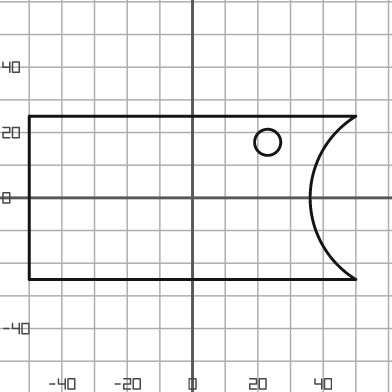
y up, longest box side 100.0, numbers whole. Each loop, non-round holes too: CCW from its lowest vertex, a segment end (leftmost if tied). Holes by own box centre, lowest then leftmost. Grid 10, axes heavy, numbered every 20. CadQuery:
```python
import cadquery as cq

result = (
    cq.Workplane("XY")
    .moveTo(-50.0, -25.0)
    .lineTo(50.0, -25.0)
    .threePointArc((36.0, 0.0), (50.0, 25.0))
    .lineTo(-50.0, 25.0)
    .close()
    .moveTo(23.0, 17.0)
    .circle(4.0)
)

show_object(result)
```